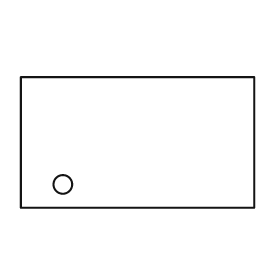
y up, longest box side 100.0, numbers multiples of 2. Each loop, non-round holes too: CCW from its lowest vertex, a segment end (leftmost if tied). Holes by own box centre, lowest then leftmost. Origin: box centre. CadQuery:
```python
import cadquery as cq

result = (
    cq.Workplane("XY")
    .moveTo(-50.0, -28.0)
    .lineTo(50.0, -28.0)
    .lineTo(50.0, 28.0)
    .lineTo(-50.0, 28.0)
    .close()
    .moveTo(-32.0, -18.0)
    .circle(4.0)
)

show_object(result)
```